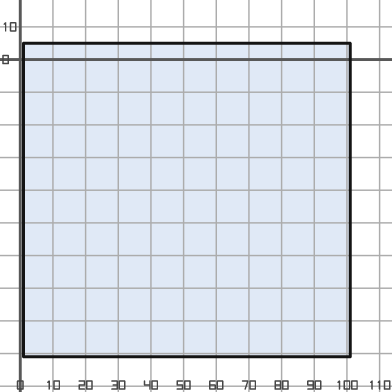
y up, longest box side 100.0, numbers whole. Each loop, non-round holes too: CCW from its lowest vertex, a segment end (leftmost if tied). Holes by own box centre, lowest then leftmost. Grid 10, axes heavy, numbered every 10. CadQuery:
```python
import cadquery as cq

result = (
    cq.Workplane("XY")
    .moveTo(1.0, -91.0)
    .lineTo(101.0, -91.0)
    .lineTo(101.0, 5.0)
    .lineTo(1.0, 5.0)
    .close()
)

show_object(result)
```